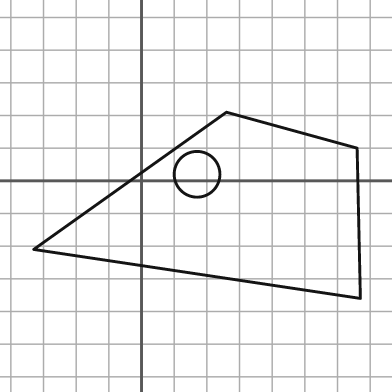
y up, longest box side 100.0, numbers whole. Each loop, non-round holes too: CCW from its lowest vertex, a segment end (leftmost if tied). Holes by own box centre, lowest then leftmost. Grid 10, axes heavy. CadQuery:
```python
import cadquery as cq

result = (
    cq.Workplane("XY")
    .moveTo(67.0, -36.0)
    .lineTo(66.0, 10.0)
    .lineTo(26.0, 21.0)
    .lineTo(-33.0, -21.0)
    .close()
    .moveTo(17.0, 2.0)
    .circle(7.0)
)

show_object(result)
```